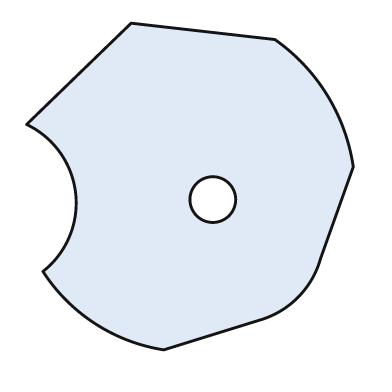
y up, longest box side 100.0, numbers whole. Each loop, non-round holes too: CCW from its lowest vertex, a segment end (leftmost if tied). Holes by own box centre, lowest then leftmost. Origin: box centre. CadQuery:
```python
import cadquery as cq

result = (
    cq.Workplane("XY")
    .moveTo(-8.0, -50.0)
    .lineTo(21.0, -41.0)
    .threePointArc((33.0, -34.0), (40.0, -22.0))
    .lineTo(50.0, 6.0)
    .threePointArc((42.0, 28.0), (26.0, 45.0))
    .lineTo(-18.0, 50.0)
    .lineTo(-50.0, 19.0)
    .threePointArc((-35.0, -2.0), (-45.0, -26.0))
    .threePointArc((-29.0, -42.0), (-8.0, -50.0))
    .close()
    .moveTo(7.0, -4.0)
    .circle(7.0)
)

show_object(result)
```